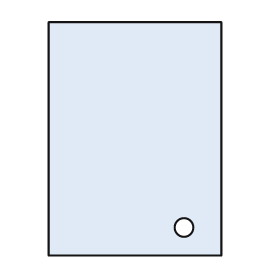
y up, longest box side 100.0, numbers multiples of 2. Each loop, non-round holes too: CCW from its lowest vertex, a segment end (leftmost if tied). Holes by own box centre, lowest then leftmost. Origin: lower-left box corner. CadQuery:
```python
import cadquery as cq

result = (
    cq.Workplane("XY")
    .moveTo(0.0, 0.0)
    .lineTo(74.0, 0.0)
    .lineTo(74.0, 100.0)
    .lineTo(0.0, 100.0)
    .close()
    .moveTo(58.0, 12.0)
    .circle(4.0)
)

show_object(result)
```